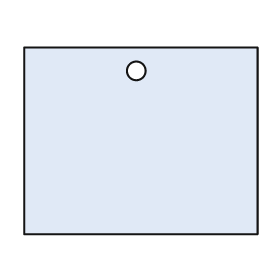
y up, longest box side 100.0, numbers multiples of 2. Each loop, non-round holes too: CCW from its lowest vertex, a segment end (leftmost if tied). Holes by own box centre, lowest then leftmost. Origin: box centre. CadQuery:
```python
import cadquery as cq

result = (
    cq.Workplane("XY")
    .moveTo(-50.0, -40.0)
    .lineTo(50.0, -40.0)
    .lineTo(50.0, 40.0)
    .lineTo(-50.0, 40.0)
    .close()
    .moveTo(-2.0, 30.0)
    .circle(4.0)
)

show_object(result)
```